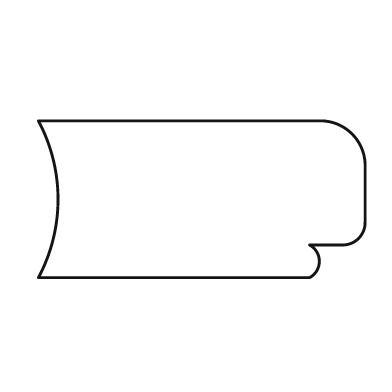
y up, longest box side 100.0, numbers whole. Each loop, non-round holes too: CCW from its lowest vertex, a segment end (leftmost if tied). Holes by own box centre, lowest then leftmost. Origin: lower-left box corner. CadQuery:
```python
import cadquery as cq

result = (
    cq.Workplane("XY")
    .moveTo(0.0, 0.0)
    .lineTo(83.0, 0.0)
    .threePointArc((86.0, 5.0), (83.0, 10.0))
    .lineTo(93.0, 10.0)
    .threePointArc((98.0, 12.0), (100.0, 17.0))
    .lineTo(100.0, 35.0)
    .threePointArc((96.0, 44.0), (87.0, 48.0))
    .lineTo(0.0, 48.0)
    .threePointArc((6.0, 24.0), (0.0, 0.0))
    .close()
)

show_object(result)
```